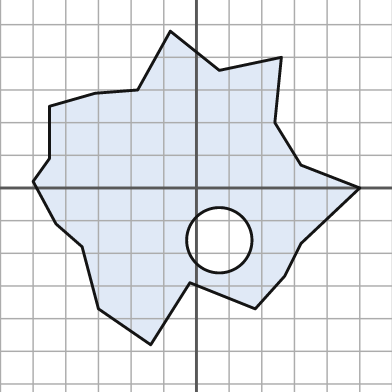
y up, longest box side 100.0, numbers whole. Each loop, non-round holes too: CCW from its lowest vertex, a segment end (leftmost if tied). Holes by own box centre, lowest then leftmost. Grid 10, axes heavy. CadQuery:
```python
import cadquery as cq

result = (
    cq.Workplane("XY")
    .moveTo(-14.0, -48.0)
    .lineTo(-2.0, -29.0)
    .lineTo(18.0, -37.0)
    .lineTo(27.0, -27.0)
    .lineTo(32.0, -17.0)
    .lineTo(50.0, 0.0)
    .lineTo(32.0, 7.0)
    .lineTo(24.0, 20.0)
    .lineTo(26.0, 40.0)
    .lineTo(7.0, 36.0)
    .lineTo(-8.0, 48.0)
    .lineTo(-18.0, 30.0)
    .lineTo(-31.0, 29.0)
    .lineTo(-45.0, 25.0)
    .lineTo(-45.0, 9.0)
    .lineTo(-50.0, 2.0)
    .lineTo(-43.0, -11.0)
    .lineTo(-35.0, -18.0)
    .lineTo(-30.0, -37.0)
    .close()
    .moveTo(7.0, -16.0)
    .circle(10.0)
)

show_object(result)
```